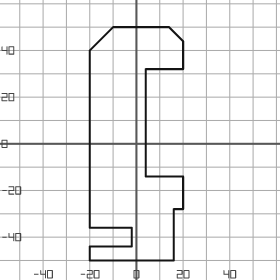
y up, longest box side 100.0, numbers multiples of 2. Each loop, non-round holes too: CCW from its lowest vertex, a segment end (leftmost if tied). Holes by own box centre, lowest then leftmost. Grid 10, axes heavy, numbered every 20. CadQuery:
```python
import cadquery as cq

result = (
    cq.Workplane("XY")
    .moveTo(-20.0, -50.0)
    .lineTo(16.0, -50.0)
    .lineTo(16.0, -28.0)
    .lineTo(20.0, -28.0)
    .lineTo(20.0, -14.0)
    .lineTo(4.0, -14.0)
    .lineTo(4.0, 32.0)
    .lineTo(20.0, 32.0)
    .lineTo(20.0, 44.0)
    .lineTo(14.0, 50.0)
    .lineTo(-10.0, 50.0)
    .lineTo(-20.0, 40.0)
    .lineTo(-20.0, -36.0)
    .lineTo(-2.0, -36.0)
    .lineTo(-2.0, -44.0)
    .lineTo(-20.0, -44.0)
    .close()
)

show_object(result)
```